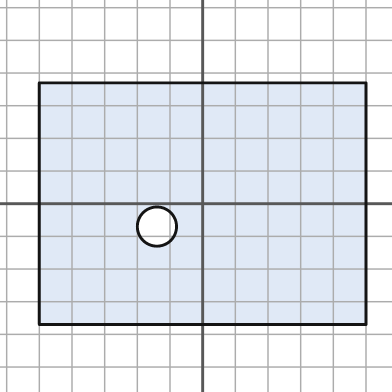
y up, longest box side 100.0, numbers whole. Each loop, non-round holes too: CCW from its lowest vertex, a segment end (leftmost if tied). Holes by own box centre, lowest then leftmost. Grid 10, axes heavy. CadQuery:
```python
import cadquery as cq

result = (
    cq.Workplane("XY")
    .moveTo(-50.0, -37.0)
    .lineTo(50.0, -37.0)
    .lineTo(50.0, 37.0)
    .lineTo(-50.0, 37.0)
    .close()
    .moveTo(-14.0, -7.0)
    .circle(6.0)
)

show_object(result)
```